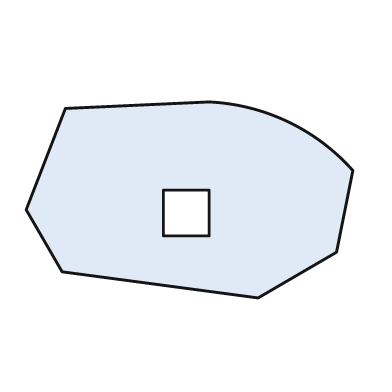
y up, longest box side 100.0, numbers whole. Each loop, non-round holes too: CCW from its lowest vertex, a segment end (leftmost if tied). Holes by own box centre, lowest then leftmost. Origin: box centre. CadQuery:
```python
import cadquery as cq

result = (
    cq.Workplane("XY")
    .moveTo(21.0, -30.0)
    .lineTo(45.0, -16.0)
    .lineTo(50.0, 9.0)
    .threePointArc((30.0, 24.0), (6.0, 30.0))
    .lineTo(-38.0, 28.0)
    .lineTo(-50.0, -3.0)
    .lineTo(-39.0, -22.0)
    .close()
    .moveTo(-8.0, -11.0)
    .lineTo(6.0, -11.0)
    .lineTo(6.0, 3.0)
    .lineTo(-8.0, 3.0)
    .close()
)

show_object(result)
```